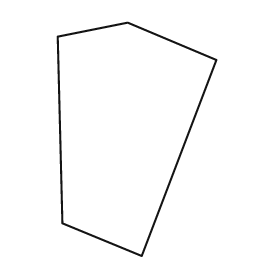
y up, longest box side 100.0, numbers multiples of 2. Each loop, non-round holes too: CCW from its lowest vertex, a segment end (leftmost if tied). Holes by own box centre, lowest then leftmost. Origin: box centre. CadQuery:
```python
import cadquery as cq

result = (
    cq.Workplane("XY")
    .moveTo(2.0, -50.0)
    .lineTo(34.0, 34.0)
    .lineTo(-4.0, 50.0)
    .lineTo(-34.0, 44.0)
    .lineTo(-32.0, -36.0)
    .close()
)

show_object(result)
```